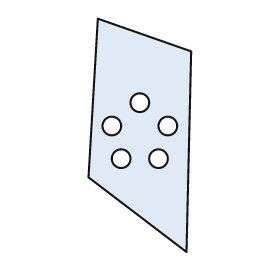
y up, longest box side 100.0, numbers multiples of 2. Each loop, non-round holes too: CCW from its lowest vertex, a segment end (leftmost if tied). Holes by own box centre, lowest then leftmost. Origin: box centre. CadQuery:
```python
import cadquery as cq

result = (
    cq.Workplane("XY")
    .moveTo(20.0, -50.0)
    .lineTo(22.0, 36.0)
    .lineTo(-18.0, 50.0)
    .lineTo(-22.0, -18.0)
    .close()
    .moveTo(-8.0, -10.0)
    .circle(4.0)
    .moveTo(8.0, -10.0)
    .circle(4.0)
    .moveTo(-12.0, 4.0)
    .circle(4.0)
    .moveTo(12.0, 4.0)
    .circle(4.0)
    .moveTo(0.0, 14.0)
    .circle(4.0)
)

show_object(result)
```